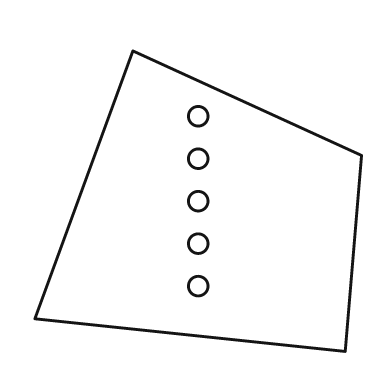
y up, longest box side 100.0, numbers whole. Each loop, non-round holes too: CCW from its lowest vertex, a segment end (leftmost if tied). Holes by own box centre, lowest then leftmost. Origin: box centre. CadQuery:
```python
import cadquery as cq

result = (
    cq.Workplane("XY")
    .moveTo(45.0, -46.0)
    .lineTo(50.0, 14.0)
    .lineTo(-20.0, 46.0)
    .lineTo(-50.0, -36.0)
    .close()
    .moveTo(0.0, -26.0)
    .circle(3.0)
    .moveTo(0.0, -13.0)
    .circle(3.0)
    .moveTo(0.0, 0.0)
    .circle(3.0)
    .moveTo(0.0, 13.0)
    .circle(3.0)
    .moveTo(0.0, 26.0)
    .circle(3.0)
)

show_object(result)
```